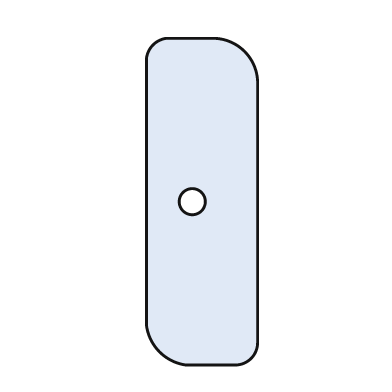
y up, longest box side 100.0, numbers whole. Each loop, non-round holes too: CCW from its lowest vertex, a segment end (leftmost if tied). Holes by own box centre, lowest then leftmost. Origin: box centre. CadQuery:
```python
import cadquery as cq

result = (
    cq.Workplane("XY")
    .moveTo(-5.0, -50.0)
    .lineTo(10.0, -50.0)
    .threePointArc((15.0, -48.0), (17.0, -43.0))
    .lineTo(17.0, 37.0)
    .threePointArc((13.0, 46.0), (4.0, 50.0))
    .lineTo(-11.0, 50.0)
    .threePointArc((-15.0, 48.0), (-17.0, 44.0))
    .lineTo(-17.0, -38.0)
    .threePointArc((-13.0, -46.0), (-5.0, -50.0))
    .close()
    .moveTo(-3.0, 0.0)
    .circle(4.0)
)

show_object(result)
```